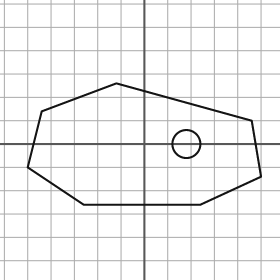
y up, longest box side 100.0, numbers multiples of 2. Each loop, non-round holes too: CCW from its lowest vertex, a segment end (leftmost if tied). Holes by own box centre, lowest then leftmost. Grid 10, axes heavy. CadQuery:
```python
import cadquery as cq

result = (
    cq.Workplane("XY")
    .moveTo(-26.0, -26.0)
    .lineTo(24.0, -26.0)
    .lineTo(50.0, -14.0)
    .lineTo(46.0, 10.0)
    .lineTo(-12.0, 26.0)
    .lineTo(-44.0, 14.0)
    .lineTo(-50.0, -10.0)
    .close()
    .moveTo(18.0, 0.0)
    .circle(6.0)
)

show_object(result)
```